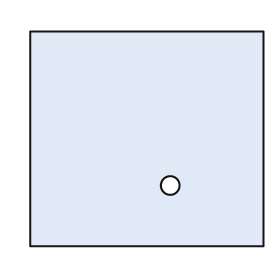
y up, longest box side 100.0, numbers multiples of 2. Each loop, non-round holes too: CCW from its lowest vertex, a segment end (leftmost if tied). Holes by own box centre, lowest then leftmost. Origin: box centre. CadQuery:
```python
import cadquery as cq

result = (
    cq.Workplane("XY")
    .moveTo(-50.0, -46.0)
    .lineTo(50.0, -46.0)
    .lineTo(50.0, 46.0)
    .lineTo(-50.0, 46.0)
    .close()
    .moveTo(10.0, -20.0)
    .circle(4.0)
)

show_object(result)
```